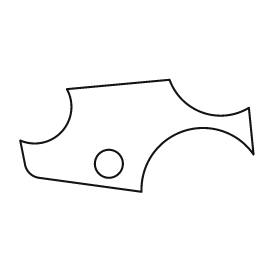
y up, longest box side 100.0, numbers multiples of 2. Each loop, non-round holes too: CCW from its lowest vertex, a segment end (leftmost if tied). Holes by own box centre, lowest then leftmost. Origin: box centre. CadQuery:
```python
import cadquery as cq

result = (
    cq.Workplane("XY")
    .moveTo(2.0, -24.0)
    .threePointArc((20.0, 2.0), (50.0, -8.0))
    .lineTo(48.0, 12.0)
    .threePointArc((28.0, 10.0), (14.0, 24.0))
    .lineTo(-30.0, 20.0)
    .threePointArc((-32.0, 2.0), (-50.0, -2.0))
    .lineTo(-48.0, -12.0)
    .threePointArc((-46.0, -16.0), (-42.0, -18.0))
    .close()
    .moveTo(-12.0, -12.0)
    .circle(6.0)
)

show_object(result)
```